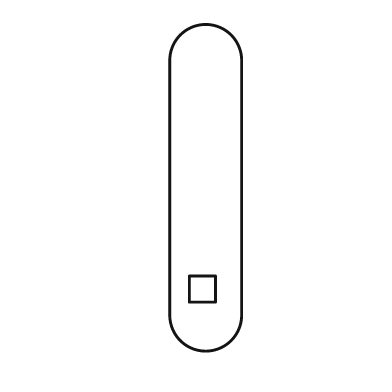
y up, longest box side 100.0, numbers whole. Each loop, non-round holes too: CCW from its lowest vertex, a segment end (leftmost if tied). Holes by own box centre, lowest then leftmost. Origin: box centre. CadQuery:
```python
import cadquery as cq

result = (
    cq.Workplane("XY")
    .moveTo(-11.0, -39.0)
    .threePointArc((0.0, -50.0), (11.0, -39.0))
    .lineTo(11.0, 39.0)
    .threePointArc((0.0, 50.0), (-11.0, 39.0))
    .close()
    .moveTo(-5.0, -35.0)
    .lineTo(3.0, -35.0)
    .lineTo(3.0, -27.0)
    .lineTo(-5.0, -27.0)
    .close()
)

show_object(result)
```